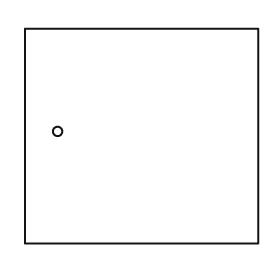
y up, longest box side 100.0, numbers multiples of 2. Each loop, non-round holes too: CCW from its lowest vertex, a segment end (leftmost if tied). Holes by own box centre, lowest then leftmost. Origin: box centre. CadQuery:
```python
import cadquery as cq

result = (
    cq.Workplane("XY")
    .moveTo(-50.0, -46.0)
    .lineTo(50.0, -46.0)
    .lineTo(50.0, 46.0)
    .lineTo(-50.0, 46.0)
    .close()
    .moveTo(-36.0, 2.0)
    .circle(2.0)
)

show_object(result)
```